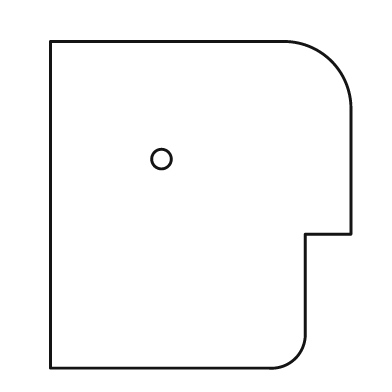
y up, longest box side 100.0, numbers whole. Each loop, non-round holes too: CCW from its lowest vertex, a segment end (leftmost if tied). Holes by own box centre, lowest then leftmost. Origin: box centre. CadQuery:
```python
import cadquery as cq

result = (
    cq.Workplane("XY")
    .moveTo(-46.0, -50.0)
    .lineTo(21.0, -50.0)
    .threePointArc((29.0, -47.0), (32.0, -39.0))
    .lineTo(32.0, -9.0)
    .lineTo(46.0, -9.0)
    .lineTo(46.0, 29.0)
    .threePointArc((40.0, 44.0), (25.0, 50.0))
    .lineTo(-46.0, 50.0)
    .close()
    .moveTo(-12.0, 14.0)
    .circle(3.0)
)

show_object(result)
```